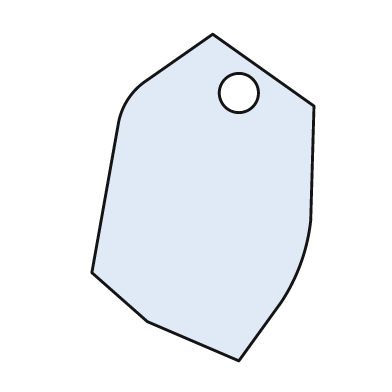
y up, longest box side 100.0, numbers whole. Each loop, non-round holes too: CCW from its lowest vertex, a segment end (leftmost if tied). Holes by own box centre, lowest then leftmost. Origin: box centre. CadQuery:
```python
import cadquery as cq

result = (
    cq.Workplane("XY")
    .moveTo(11.0, -50.0)
    .lineTo(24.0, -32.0)
    .threePointArc((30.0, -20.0), (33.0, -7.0))
    .lineTo(34.0, 28.0)
    .lineTo(3.0, 50.0)
    .lineTo(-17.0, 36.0)
    .threePointArc((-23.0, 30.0), (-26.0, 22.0))
    .lineTo(-34.0, -23.0)
    .lineTo(-17.0, -38.0)
    .close()
    .moveTo(11.0, 32.0)
    .circle(6.0)
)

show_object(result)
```